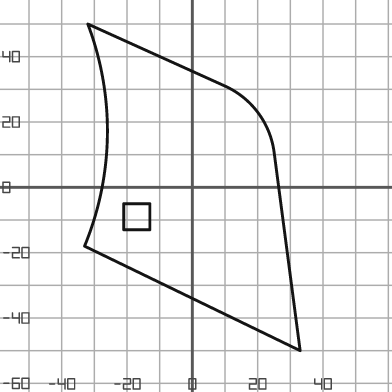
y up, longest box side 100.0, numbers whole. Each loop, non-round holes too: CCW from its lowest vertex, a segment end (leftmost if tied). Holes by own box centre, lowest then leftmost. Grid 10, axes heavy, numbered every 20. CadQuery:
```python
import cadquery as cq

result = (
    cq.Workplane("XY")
    .moveTo(33.0, -50.0)
    .lineTo(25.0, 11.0)
    .threePointArc((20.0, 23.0), (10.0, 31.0))
    .lineTo(-32.0, 50.0)
    .threePointArc((-26.0, 16.0), (-33.0, -18.0))
    .close()
    .moveTo(-21.0, -13.0)
    .lineTo(-13.0, -13.0)
    .lineTo(-13.0, -5.0)
    .lineTo(-21.0, -5.0)
    .close()
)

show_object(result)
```